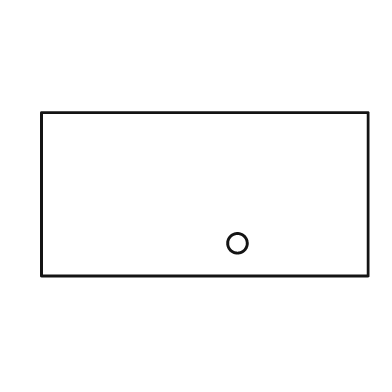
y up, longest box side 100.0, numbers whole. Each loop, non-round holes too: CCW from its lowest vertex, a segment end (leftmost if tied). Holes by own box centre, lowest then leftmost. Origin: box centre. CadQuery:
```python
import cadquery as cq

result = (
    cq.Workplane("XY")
    .moveTo(-50.0, -25.0)
    .lineTo(50.0, -25.0)
    .lineTo(50.0, 25.0)
    .lineTo(-50.0, 25.0)
    .close()
    .moveTo(10.0, -15.0)
    .circle(3.0)
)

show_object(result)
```